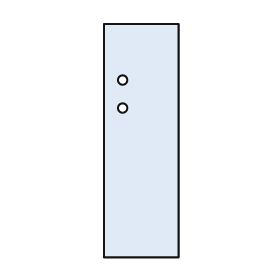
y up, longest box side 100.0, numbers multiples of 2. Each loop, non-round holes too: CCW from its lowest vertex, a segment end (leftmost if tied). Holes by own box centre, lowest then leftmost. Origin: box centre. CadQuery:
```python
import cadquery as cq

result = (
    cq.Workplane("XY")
    .moveTo(-16.0, -50.0)
    .lineTo(16.0, -50.0)
    .lineTo(16.0, 50.0)
    .lineTo(-16.0, 50.0)
    .close()
    .moveTo(-8.0, 14.0)
    .circle(2.0)
    .moveTo(-8.0, 26.0)
    .circle(2.0)
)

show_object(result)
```